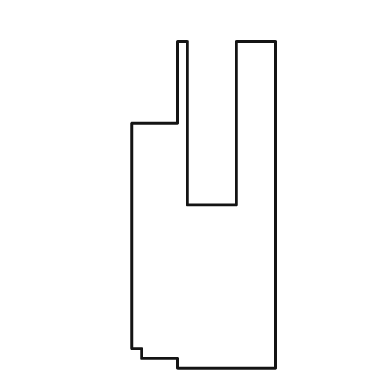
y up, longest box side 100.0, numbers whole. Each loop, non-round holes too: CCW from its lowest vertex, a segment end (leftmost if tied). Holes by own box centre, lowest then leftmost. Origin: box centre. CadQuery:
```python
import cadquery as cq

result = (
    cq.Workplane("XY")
    .moveTo(-8.0, -50.0)
    .lineTo(22.0, -50.0)
    .lineTo(22.0, 50.0)
    .lineTo(10.0, 50.0)
    .lineTo(10.0, 0.0)
    .lineTo(-5.0, 0.0)
    .lineTo(-5.0, 50.0)
    .lineTo(-8.0, 50.0)
    .lineTo(-8.0, 25.0)
    .lineTo(-22.0, 25.0)
    .lineTo(-22.0, -44.0)
    .lineTo(-19.0, -44.0)
    .lineTo(-19.0, -47.0)
    .lineTo(-8.0, -47.0)
    .close()
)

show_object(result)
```